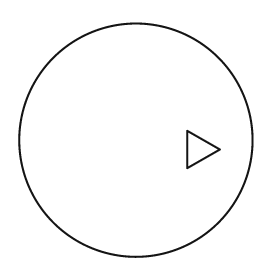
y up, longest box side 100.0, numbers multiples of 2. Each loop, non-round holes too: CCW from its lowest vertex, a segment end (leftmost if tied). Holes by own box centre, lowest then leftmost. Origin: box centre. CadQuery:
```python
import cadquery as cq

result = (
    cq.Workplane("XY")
    .moveTo(0.0, 0.0)
    .circle(50.0)
    .moveTo(22.0, -12.0)
    .lineTo(36.0, -4.0)
    .lineTo(22.0, 4.0)
    .close()
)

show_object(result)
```